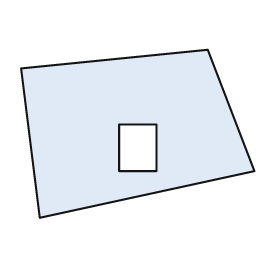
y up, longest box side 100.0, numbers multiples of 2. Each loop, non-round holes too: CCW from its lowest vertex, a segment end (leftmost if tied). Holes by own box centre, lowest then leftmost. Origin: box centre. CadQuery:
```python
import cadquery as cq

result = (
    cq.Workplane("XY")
    .moveTo(-42.0, -36.0)
    .lineTo(50.0, -16.0)
    .lineTo(30.0, 36.0)
    .lineTo(-50.0, 28.0)
    .close()
    .moveTo(-8.0, -16.0)
    .lineTo(8.0, -16.0)
    .lineTo(8.0, 4.0)
    .lineTo(-8.0, 4.0)
    .close()
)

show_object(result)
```